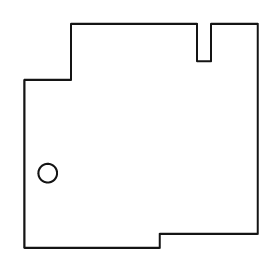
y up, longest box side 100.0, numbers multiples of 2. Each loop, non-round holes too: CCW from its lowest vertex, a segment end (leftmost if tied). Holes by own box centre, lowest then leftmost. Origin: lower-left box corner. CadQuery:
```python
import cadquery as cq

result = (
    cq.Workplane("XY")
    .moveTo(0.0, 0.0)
    .lineTo(58.0, 0.0)
    .lineTo(58.0, 6.0)
    .lineTo(100.0, 6.0)
    .lineTo(100.0, 96.0)
    .lineTo(80.0, 96.0)
    .lineTo(80.0, 80.0)
    .lineTo(74.0, 80.0)
    .lineTo(74.0, 96.0)
    .lineTo(20.0, 96.0)
    .lineTo(20.0, 72.0)
    .lineTo(0.0, 72.0)
    .close()
    .moveTo(10.0, 32.0)
    .circle(4.0)
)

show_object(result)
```